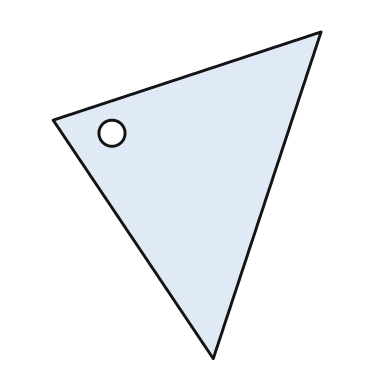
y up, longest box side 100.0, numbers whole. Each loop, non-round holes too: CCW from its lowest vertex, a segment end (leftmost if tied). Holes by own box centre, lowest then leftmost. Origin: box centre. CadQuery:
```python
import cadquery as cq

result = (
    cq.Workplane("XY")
    .moveTo(8.0, -50.0)
    .lineTo(41.0, 50.0)
    .lineTo(-41.0, 23.0)
    .close()
    .moveTo(-23.0, 19.0)
    .circle(4.0)
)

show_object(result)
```